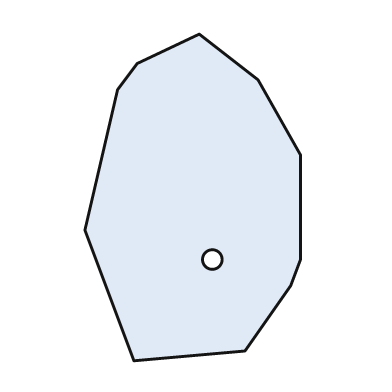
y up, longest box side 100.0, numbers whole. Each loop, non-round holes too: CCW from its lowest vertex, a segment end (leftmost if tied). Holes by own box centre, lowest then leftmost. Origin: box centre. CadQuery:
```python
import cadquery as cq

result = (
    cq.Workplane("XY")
    .moveTo(-18.0, -50.0)
    .lineTo(16.0, -47.0)
    .lineTo(30.0, -27.0)
    .lineTo(33.0, -19.0)
    .lineTo(33.0, 13.0)
    .lineTo(20.0, 36.0)
    .lineTo(2.0, 50.0)
    .lineTo(-17.0, 41.0)
    .lineTo(-23.0, 33.0)
    .lineTo(-33.0, -10.0)
    .close()
    .moveTo(6.0, -19.0)
    .circle(3.0)
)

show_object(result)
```